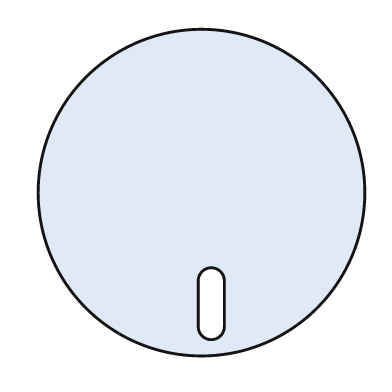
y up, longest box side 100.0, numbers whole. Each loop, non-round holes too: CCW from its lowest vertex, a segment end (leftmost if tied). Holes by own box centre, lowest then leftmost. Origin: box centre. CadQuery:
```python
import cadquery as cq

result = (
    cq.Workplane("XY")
    .moveTo(0.0, 0.0)
    .circle(50.0)
    .moveTo(-1.0, -41.0)
    .threePointArc((3.0, -45.0), (7.0, -41.0))
    .lineTo(7.0, -27.0)
    .threePointArc((3.0, -23.0), (-1.0, -27.0))
    .close()
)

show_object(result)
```